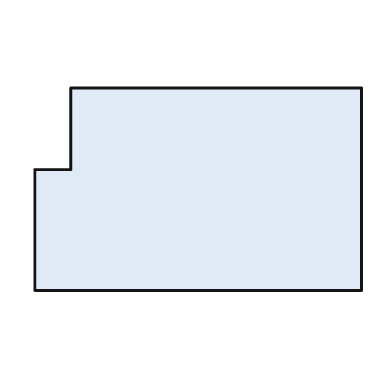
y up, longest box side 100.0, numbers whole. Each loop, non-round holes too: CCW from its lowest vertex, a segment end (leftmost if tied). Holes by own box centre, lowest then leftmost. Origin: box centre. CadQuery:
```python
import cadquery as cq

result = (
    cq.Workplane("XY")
    .moveTo(-50.0, -31.0)
    .lineTo(50.0, -31.0)
    .lineTo(50.0, 31.0)
    .lineTo(-39.0, 31.0)
    .lineTo(-39.0, 6.0)
    .lineTo(-50.0, 6.0)
    .close()
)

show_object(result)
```